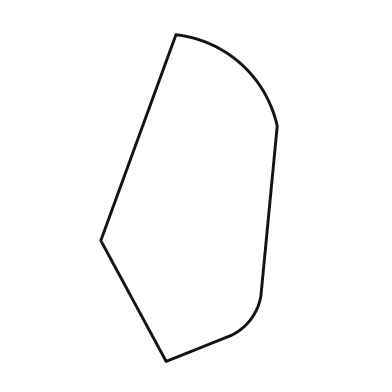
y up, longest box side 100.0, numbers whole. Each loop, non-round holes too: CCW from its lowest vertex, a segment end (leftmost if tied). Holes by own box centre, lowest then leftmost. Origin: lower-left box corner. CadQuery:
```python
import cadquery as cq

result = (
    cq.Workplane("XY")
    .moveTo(20.0, 0.0)
    .lineTo(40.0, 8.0)
    .threePointArc((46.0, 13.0), (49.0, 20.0))
    .lineTo(54.0, 72.0)
    .threePointArc((43.0, 91.0), (23.0, 100.0))
    .lineTo(0.0, 37.0)
    .close()
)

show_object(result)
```